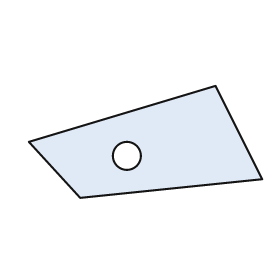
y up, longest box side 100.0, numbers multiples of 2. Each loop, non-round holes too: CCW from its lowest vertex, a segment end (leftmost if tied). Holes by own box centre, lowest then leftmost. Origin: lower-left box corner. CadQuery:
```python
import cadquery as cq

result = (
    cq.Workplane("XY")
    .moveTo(22.0, 0.0)
    .lineTo(100.0, 8.0)
    .lineTo(80.0, 48.0)
    .lineTo(0.0, 24.0)
    .close()
    .moveTo(42.0, 18.0)
    .circle(6.0)
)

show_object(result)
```